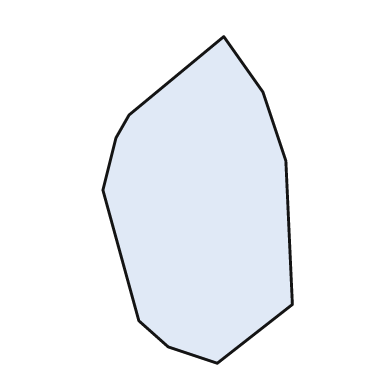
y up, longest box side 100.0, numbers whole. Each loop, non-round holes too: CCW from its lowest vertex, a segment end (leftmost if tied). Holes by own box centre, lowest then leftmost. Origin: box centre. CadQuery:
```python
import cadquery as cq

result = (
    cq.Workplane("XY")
    .moveTo(6.0, -50.0)
    .lineTo(29.0, -32.0)
    .lineTo(27.0, 12.0)
    .lineTo(20.0, 33.0)
    .lineTo(8.0, 50.0)
    .lineTo(-21.0, 26.0)
    .lineTo(-25.0, 19.0)
    .lineTo(-29.0, 3.0)
    .lineTo(-18.0, -37.0)
    .lineTo(-9.0, -45.0)
    .close()
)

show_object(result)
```